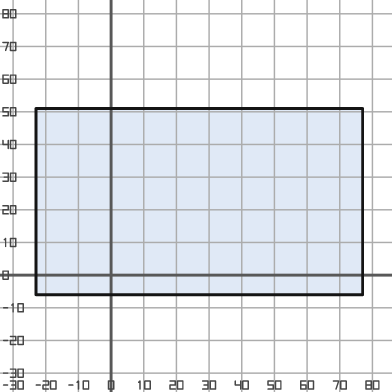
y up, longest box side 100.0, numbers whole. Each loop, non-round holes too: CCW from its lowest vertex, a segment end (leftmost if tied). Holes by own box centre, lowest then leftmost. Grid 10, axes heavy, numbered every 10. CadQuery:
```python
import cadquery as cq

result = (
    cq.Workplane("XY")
    .moveTo(-23.0, -6.0)
    .lineTo(77.0, -6.0)
    .lineTo(77.0, 51.0)
    .lineTo(-23.0, 51.0)
    .close()
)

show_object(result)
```